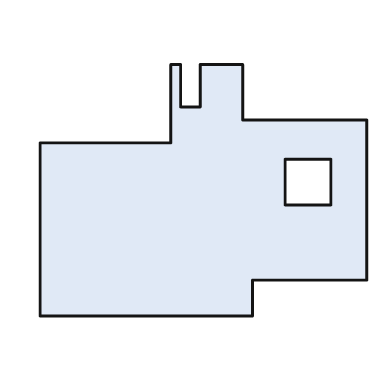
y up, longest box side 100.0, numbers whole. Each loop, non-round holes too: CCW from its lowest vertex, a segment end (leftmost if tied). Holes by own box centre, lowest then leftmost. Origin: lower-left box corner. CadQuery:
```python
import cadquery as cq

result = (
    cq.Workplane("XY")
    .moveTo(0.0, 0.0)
    .lineTo(65.0, 0.0)
    .lineTo(65.0, 11.0)
    .lineTo(100.0, 11.0)
    .lineTo(100.0, 60.0)
    .lineTo(62.0, 60.0)
    .lineTo(62.0, 77.0)
    .lineTo(49.0, 77.0)
    .lineTo(49.0, 64.0)
    .lineTo(43.0, 64.0)
    .lineTo(43.0, 77.0)
    .lineTo(40.0, 77.0)
    .lineTo(40.0, 53.0)
    .lineTo(0.0, 53.0)
    .close()
    .moveTo(75.0, 34.0)
    .lineTo(89.0, 34.0)
    .lineTo(89.0, 48.0)
    .lineTo(75.0, 48.0)
    .close()
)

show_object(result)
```